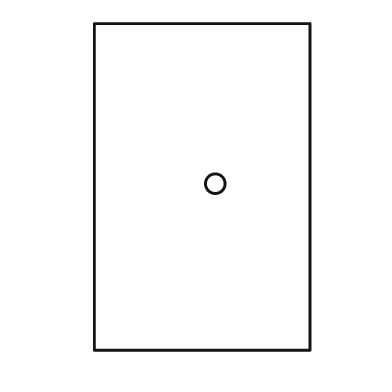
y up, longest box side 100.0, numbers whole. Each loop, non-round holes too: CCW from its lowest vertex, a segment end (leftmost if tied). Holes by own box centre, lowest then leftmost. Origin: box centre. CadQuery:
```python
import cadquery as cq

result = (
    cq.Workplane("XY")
    .moveTo(-33.0, -50.0)
    .lineTo(33.0, -50.0)
    .lineTo(33.0, 50.0)
    .lineTo(-33.0, 50.0)
    .close()
    .moveTo(4.0, 1.0)
    .circle(3.0)
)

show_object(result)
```